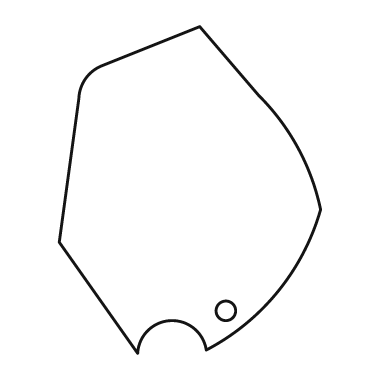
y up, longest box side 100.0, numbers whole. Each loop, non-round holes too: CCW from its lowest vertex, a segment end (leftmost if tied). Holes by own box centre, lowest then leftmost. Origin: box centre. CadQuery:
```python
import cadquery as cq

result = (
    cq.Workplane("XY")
    .moveTo(-16.0, -50.0)
    .threePointArc((-6.0, -40.0), (5.0, -49.0))
    .threePointArc((27.0, -31.0), (40.0, -6.0))
    .threePointArc((33.0, 13.0), (21.0, 29.0))
    .lineTo(3.0, 50.0)
    .lineTo(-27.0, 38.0)
    .threePointArc((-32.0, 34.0), (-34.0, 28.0))
    .lineTo(-40.0, -16.0)
    .close()
    .moveTo(11.0, -37.0)
    .circle(3.0)
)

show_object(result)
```